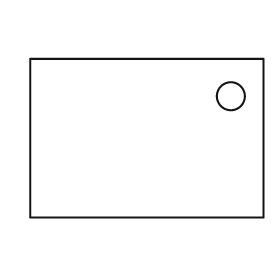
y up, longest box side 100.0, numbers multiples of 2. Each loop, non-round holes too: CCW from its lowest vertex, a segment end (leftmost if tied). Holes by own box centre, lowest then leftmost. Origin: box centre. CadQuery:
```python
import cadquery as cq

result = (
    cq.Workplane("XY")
    .moveTo(-50.0, -34.0)
    .lineTo(50.0, -34.0)
    .lineTo(50.0, 34.0)
    .lineTo(-50.0, 34.0)
    .close()
    .moveTo(36.0, 18.0)
    .circle(6.0)
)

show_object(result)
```